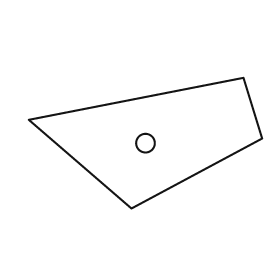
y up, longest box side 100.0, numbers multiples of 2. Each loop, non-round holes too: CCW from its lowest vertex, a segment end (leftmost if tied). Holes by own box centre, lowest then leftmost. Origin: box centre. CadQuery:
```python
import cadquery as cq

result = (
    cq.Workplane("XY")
    .moveTo(-6.0, -28.0)
    .lineTo(50.0, 2.0)
    .lineTo(42.0, 28.0)
    .lineTo(-50.0, 10.0)
    .close()
    .moveTo(0.0, 0.0)
    .circle(4.0)
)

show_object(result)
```